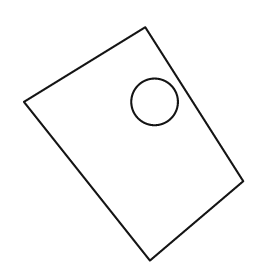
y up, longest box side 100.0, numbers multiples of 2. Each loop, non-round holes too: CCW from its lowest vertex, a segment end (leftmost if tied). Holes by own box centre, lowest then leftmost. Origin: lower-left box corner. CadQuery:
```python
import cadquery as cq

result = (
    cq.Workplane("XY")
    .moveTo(54.0, 0.0)
    .lineTo(94.0, 34.0)
    .lineTo(52.0, 100.0)
    .lineTo(0.0, 68.0)
    .close()
    .moveTo(56.0, 68.0)
    .circle(10.0)
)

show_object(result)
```